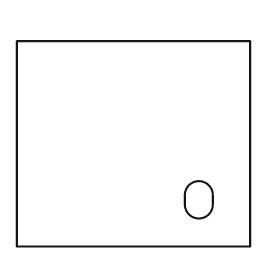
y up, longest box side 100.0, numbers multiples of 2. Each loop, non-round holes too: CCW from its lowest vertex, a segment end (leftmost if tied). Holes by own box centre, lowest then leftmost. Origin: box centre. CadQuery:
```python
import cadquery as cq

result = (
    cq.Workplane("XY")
    .moveTo(-50.0, -44.0)
    .lineTo(50.0, -44.0)
    .lineTo(50.0, 44.0)
    .lineTo(-50.0, 44.0)
    .close()
    .moveTo(22.0, -26.0)
    .threePointArc((28.0, -32.0), (34.0, -26.0))
    .lineTo(34.0, -22.0)
    .threePointArc((28.0, -16.0), (22.0, -22.0))
    .close()
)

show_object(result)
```